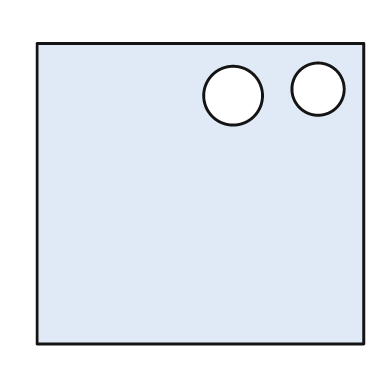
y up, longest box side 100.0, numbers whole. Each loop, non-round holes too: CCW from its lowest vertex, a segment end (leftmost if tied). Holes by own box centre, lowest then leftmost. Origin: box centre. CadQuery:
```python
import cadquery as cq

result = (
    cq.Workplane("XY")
    .moveTo(-50.0, -46.0)
    .lineTo(50.0, -46.0)
    .lineTo(50.0, 46.0)
    .lineTo(-50.0, 46.0)
    .close()
    .moveTo(10.0, 30.0)
    .circle(9.0)
    .moveTo(36.0, 32.0)
    .circle(8.0)
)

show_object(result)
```